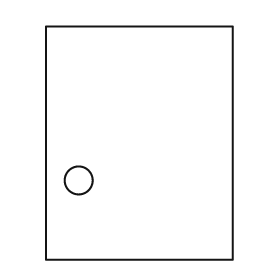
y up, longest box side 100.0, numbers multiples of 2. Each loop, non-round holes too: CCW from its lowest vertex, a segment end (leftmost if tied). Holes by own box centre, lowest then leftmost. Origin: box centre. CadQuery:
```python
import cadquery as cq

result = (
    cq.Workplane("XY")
    .moveTo(-40.0, -50.0)
    .lineTo(40.0, -50.0)
    .lineTo(40.0, 50.0)
    .lineTo(-40.0, 50.0)
    .close()
    .moveTo(-26.0, -16.0)
    .circle(6.0)
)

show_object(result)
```